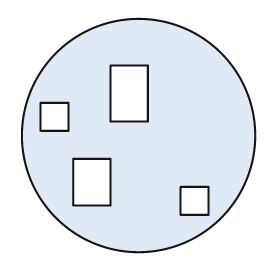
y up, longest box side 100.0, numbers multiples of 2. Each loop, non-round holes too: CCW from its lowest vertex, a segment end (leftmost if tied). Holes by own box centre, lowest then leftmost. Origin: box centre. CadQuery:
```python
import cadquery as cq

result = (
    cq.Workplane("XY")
    .moveTo(0.0, 0.0)
    .circle(50.0)
    .moveTo(18.0, -34.0)
    .lineTo(30.0, -34.0)
    .lineTo(30.0, -22.0)
    .lineTo(18.0, -22.0)
    .close()
    .moveTo(-28.0, -30.0)
    .lineTo(-12.0, -30.0)
    .lineTo(-12.0, -10.0)
    .lineTo(-28.0, -10.0)
    .close()
    .moveTo(-42.0, 2.0)
    .lineTo(-30.0, 2.0)
    .lineTo(-30.0, 14.0)
    .lineTo(-42.0, 14.0)
    .close()
    .moveTo(-12.0, 6.0)
    .lineTo(4.0, 6.0)
    .lineTo(4.0, 30.0)
    .lineTo(-12.0, 30.0)
    .close()
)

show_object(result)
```